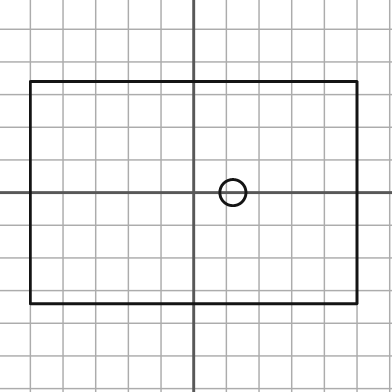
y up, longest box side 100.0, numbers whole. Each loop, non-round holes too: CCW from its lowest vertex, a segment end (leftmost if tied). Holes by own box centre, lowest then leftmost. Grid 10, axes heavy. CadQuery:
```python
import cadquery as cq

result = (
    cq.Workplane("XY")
    .moveTo(-50.0, -34.0)
    .lineTo(50.0, -34.0)
    .lineTo(50.0, 34.0)
    .lineTo(-50.0, 34.0)
    .close()
    .moveTo(12.0, 0.0)
    .circle(4.0)
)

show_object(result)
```